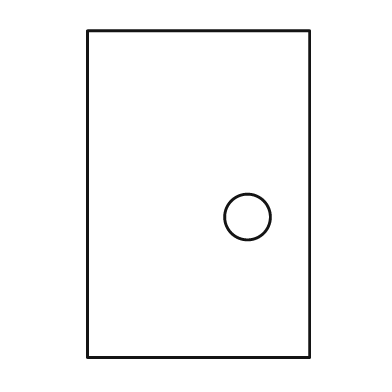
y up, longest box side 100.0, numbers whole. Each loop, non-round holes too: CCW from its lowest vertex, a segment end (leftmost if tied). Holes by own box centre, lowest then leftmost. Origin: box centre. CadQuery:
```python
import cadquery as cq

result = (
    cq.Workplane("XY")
    .moveTo(-34.0, -50.0)
    .lineTo(34.0, -50.0)
    .lineTo(34.0, 50.0)
    .lineTo(-34.0, 50.0)
    .close()
    .moveTo(15.0, -7.0)
    .circle(7.0)
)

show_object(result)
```